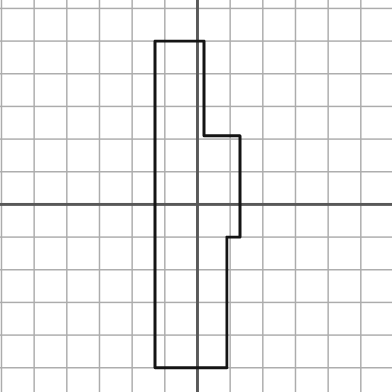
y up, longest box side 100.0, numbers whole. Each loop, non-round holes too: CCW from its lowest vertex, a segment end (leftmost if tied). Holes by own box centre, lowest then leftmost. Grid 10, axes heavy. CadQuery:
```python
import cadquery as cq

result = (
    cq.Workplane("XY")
    .moveTo(-13.0, -50.0)
    .lineTo(9.0, -50.0)
    .lineTo(9.0, -10.0)
    .lineTo(13.0, -10.0)
    .lineTo(13.0, 21.0)
    .lineTo(2.0, 21.0)
    .lineTo(2.0, 50.0)
    .lineTo(-13.0, 50.0)
    .close()
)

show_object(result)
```